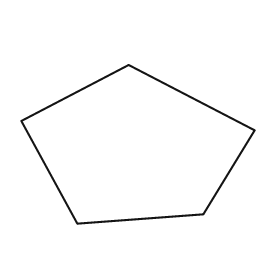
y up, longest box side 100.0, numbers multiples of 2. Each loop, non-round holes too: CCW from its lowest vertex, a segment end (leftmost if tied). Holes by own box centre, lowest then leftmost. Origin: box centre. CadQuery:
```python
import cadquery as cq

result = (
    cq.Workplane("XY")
    .moveTo(-26.0, -34.0)
    .lineTo(28.0, -30.0)
    .lineTo(50.0, 6.0)
    .lineTo(-4.0, 34.0)
    .lineTo(-50.0, 10.0)
    .close()
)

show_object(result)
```